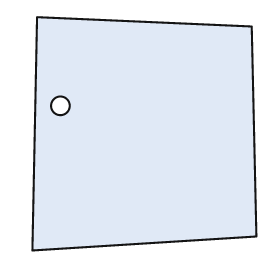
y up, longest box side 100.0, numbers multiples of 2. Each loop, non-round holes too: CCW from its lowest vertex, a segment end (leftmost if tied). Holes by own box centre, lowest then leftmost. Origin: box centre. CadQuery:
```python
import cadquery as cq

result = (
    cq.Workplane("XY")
    .moveTo(-48.0, -50.0)
    .lineTo(48.0, -44.0)
    .lineTo(46.0, 46.0)
    .lineTo(-46.0, 50.0)
    .close()
    .moveTo(-36.0, 12.0)
    .circle(4.0)
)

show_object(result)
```